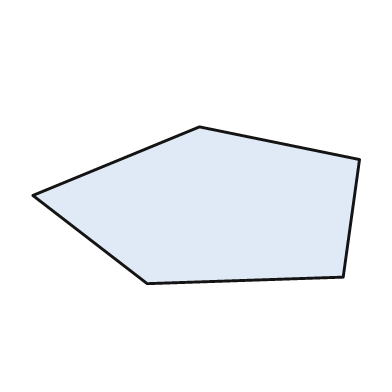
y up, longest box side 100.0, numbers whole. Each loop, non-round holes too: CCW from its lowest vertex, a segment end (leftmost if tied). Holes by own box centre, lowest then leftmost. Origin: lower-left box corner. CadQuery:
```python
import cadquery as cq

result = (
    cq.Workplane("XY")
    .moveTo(35.0, 0.0)
    .lineTo(95.0, 2.0)
    .lineTo(100.0, 38.0)
    .lineTo(51.0, 48.0)
    .lineTo(0.0, 27.0)
    .close()
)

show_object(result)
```